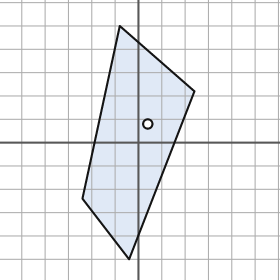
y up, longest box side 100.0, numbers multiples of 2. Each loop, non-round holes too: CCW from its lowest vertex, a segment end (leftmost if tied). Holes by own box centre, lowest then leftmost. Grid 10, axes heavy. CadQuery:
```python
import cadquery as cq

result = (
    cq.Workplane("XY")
    .moveTo(-4.0, -50.0)
    .lineTo(24.0, 22.0)
    .lineTo(-8.0, 50.0)
    .lineTo(-24.0, -24.0)
    .close()
    .moveTo(4.0, 8.0)
    .circle(2.0)
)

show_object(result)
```